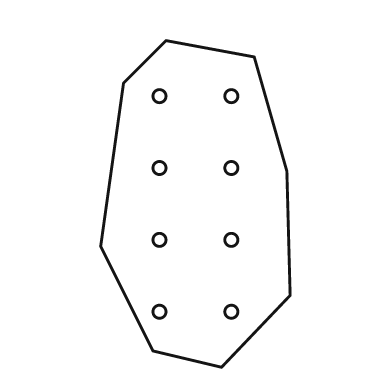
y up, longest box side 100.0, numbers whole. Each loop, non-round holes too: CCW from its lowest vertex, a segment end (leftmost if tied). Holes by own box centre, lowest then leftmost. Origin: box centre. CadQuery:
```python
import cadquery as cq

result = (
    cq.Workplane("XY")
    .moveTo(8.0, -50.0)
    .lineTo(29.0, -28.0)
    .lineTo(28.0, 10.0)
    .lineTo(18.0, 45.0)
    .lineTo(-9.0, 50.0)
    .lineTo(-22.0, 37.0)
    .lineTo(-29.0, -13.0)
    .lineTo(-13.0, -45.0)
    .close()
    .moveTo(-11.0, -33.0)
    .circle(2.0)
    .moveTo(11.0, -33.0)
    .circle(2.0)
    .moveTo(-11.0, -11.0)
    .circle(2.0)
    .moveTo(11.0, -11.0)
    .circle(2.0)
    .moveTo(-11.0, 11.0)
    .circle(2.0)
    .moveTo(11.0, 11.0)
    .circle(2.0)
    .moveTo(-11.0, 33.0)
    .circle(2.0)
    .moveTo(11.0, 33.0)
    .circle(2.0)
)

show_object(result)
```